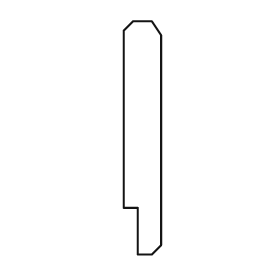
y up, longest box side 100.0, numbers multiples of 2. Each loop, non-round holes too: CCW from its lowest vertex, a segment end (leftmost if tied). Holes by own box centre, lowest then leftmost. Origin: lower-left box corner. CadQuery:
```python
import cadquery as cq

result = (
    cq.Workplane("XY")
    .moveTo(6.0, 0.0)
    .lineTo(12.0, 0.0)
    .lineTo(16.0, 4.0)
    .lineTo(16.0, 94.0)
    .lineTo(12.0, 100.0)
    .lineTo(4.0, 100.0)
    .lineTo(0.0, 96.0)
    .lineTo(0.0, 20.0)
    .lineTo(6.0, 20.0)
    .close()
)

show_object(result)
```